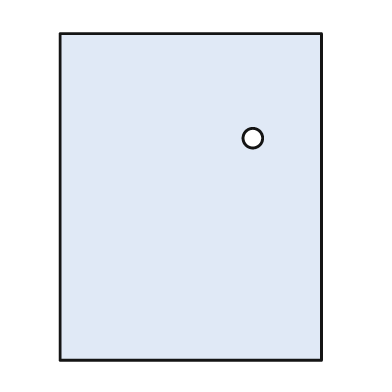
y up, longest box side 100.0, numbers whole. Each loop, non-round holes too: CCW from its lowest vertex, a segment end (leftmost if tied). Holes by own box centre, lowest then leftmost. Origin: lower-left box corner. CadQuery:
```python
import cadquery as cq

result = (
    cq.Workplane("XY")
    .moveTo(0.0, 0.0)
    .lineTo(80.0, 0.0)
    .lineTo(80.0, 100.0)
    .lineTo(0.0, 100.0)
    .close()
    .moveTo(59.0, 68.0)
    .circle(3.0)
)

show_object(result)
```